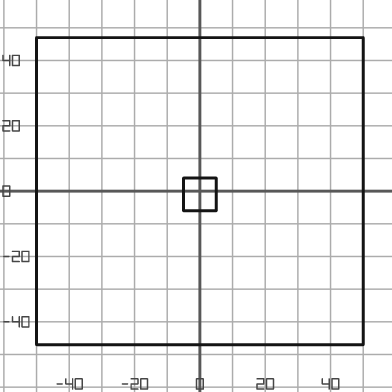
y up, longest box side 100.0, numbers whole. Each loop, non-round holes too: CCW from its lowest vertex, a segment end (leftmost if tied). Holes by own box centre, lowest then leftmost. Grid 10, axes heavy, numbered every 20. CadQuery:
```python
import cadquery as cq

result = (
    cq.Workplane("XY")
    .moveTo(-50.0, -47.0)
    .lineTo(50.0, -47.0)
    .lineTo(50.0, 47.0)
    .lineTo(-50.0, 47.0)
    .close()
    .moveTo(-5.0, -6.0)
    .lineTo(5.0, -6.0)
    .lineTo(5.0, 4.0)
    .lineTo(-5.0, 4.0)
    .close()
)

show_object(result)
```